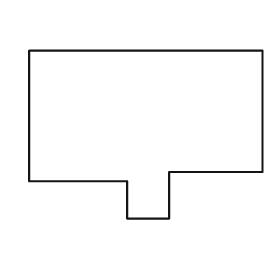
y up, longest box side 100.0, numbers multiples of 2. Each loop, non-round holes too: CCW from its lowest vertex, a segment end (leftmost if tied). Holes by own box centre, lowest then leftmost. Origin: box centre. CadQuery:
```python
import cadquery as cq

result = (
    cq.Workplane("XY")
    .moveTo(-8.0, -36.0)
    .lineTo(10.0, -36.0)
    .lineTo(10.0, -16.0)
    .lineTo(50.0, -16.0)
    .lineTo(50.0, 36.0)
    .lineTo(-50.0, 36.0)
    .lineTo(-50.0, -20.0)
    .lineTo(-8.0, -20.0)
    .close()
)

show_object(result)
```